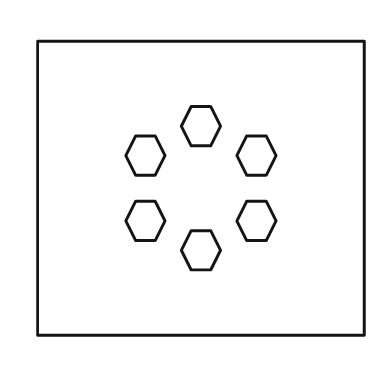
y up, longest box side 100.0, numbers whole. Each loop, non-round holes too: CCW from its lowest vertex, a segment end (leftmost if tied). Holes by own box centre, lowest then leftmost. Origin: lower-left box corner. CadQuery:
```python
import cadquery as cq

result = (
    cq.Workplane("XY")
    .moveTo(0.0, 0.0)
    .lineTo(100.0, 0.0)
    .lineTo(100.0, 90.0)
    .lineTo(0.0, 90.0)
    .close()
    .moveTo(47.0, 20.0)
    .lineTo(53.0, 20.0)
    .lineTo(56.0, 26.0)
    .lineTo(53.0, 32.0)
    .lineTo(47.0, 32.0)
    .lineTo(44.0, 26.0)
    .close()
    .moveTo(30.0, 29.0)
    .lineTo(36.0, 29.0)
    .lineTo(39.0, 35.0)
    .lineTo(36.0, 41.0)
    .lineTo(30.0, 41.0)
    .lineTo(27.0, 35.0)
    .close()
    .moveTo(64.0, 29.0)
    .lineTo(70.0, 29.0)
    .lineTo(73.0, 35.0)
    .lineTo(70.0, 41.0)
    .lineTo(64.0, 41.0)
    .lineTo(61.0, 35.0)
    .close()
    .moveTo(30.0, 49.0)
    .lineTo(36.0, 49.0)
    .lineTo(39.0, 55.0)
    .lineTo(36.0, 61.0)
    .lineTo(30.0, 61.0)
    .lineTo(27.0, 55.0)
    .close()
    .moveTo(64.0, 49.0)
    .lineTo(70.0, 49.0)
    .lineTo(73.0, 55.0)
    .lineTo(70.0, 61.0)
    .lineTo(64.0, 61.0)
    .lineTo(61.0, 55.0)
    .close()
    .moveTo(47.0, 58.0)
    .lineTo(53.0, 58.0)
    .lineTo(56.0, 64.0)
    .lineTo(53.0, 70.0)
    .lineTo(47.0, 70.0)
    .lineTo(44.0, 64.0)
    .close()
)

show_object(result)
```